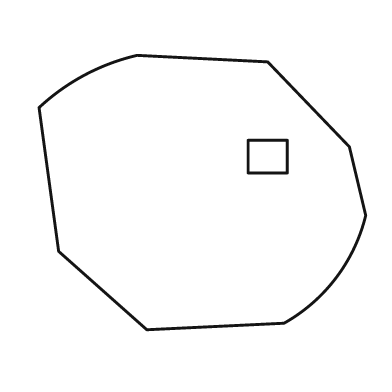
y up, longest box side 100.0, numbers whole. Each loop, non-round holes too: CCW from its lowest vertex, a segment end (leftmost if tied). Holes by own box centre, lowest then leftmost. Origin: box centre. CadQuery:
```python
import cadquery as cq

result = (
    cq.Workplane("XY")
    .moveTo(-17.0, -42.0)
    .lineTo(25.0, -40.0)
    .threePointArc((41.0, -26.0), (50.0, -7.0))
    .lineTo(45.0, 14.0)
    .lineTo(20.0, 40.0)
    .lineTo(-20.0, 42.0)
    .threePointArc((-36.0, 36.0), (-50.0, 26.0))
    .lineTo(-44.0, -18.0)
    .close()
    .moveTo(14.0, 6.0)
    .lineTo(26.0, 6.0)
    .lineTo(26.0, 16.0)
    .lineTo(14.0, 16.0)
    .close()
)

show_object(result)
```